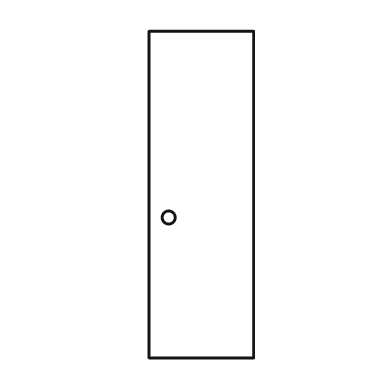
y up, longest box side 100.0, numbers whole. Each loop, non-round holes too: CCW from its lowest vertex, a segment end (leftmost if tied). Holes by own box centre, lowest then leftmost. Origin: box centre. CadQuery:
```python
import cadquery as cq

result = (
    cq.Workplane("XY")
    .moveTo(-16.0, -50.0)
    .lineTo(16.0, -50.0)
    .lineTo(16.0, 50.0)
    .lineTo(-16.0, 50.0)
    .close()
    .moveTo(-10.0, -7.0)
    .circle(2.0)
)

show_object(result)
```